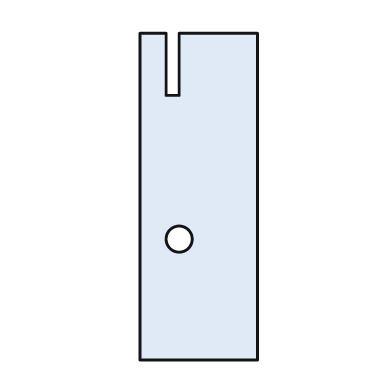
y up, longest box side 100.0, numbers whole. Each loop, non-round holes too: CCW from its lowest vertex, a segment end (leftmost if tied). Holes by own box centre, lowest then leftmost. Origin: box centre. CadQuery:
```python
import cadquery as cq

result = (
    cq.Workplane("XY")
    .moveTo(-18.0, -50.0)
    .lineTo(18.0, -50.0)
    .lineTo(18.0, 50.0)
    .lineTo(-6.0, 50.0)
    .lineTo(-6.0, 31.0)
    .lineTo(-10.0, 31.0)
    .lineTo(-10.0, 50.0)
    .lineTo(-18.0, 50.0)
    .close()
    .moveTo(-6.0, -13.0)
    .circle(4.0)
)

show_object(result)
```